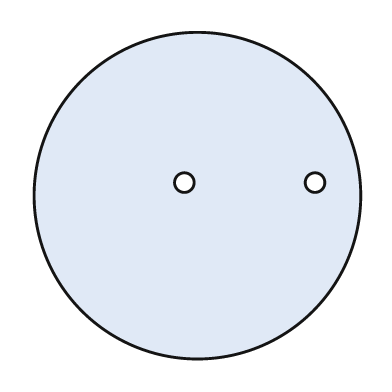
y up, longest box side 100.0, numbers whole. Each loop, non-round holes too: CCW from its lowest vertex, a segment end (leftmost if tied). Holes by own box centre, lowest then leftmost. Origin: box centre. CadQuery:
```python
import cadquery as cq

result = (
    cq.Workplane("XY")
    .moveTo(0.0, 0.0)
    .circle(50.0)
    .moveTo(-4.0, 4.0)
    .circle(3.0)
    .moveTo(36.0, 4.0)
    .circle(3.0)
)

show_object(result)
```